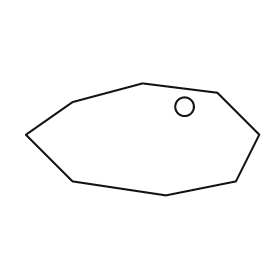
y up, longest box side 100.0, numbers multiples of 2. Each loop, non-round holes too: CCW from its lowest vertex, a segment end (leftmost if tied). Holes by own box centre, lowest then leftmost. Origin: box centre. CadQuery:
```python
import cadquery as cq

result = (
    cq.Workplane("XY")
    .moveTo(10.0, -24.0)
    .lineTo(40.0, -18.0)
    .lineTo(50.0, 2.0)
    .lineTo(32.0, 20.0)
    .lineTo(0.0, 24.0)
    .lineTo(-30.0, 16.0)
    .lineTo(-50.0, 2.0)
    .lineTo(-30.0, -18.0)
    .close()
    .moveTo(18.0, 14.0)
    .circle(4.0)
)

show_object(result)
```